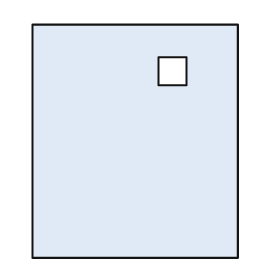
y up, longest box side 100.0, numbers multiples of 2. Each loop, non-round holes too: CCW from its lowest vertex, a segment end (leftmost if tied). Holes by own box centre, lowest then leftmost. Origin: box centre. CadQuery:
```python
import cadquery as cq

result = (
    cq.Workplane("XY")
    .moveTo(-44.0, -50.0)
    .lineTo(44.0, -50.0)
    .lineTo(44.0, 50.0)
    .lineTo(-44.0, 50.0)
    .close()
    .moveTo(10.0, 24.0)
    .lineTo(22.0, 24.0)
    .lineTo(22.0, 36.0)
    .lineTo(10.0, 36.0)
    .close()
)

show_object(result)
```